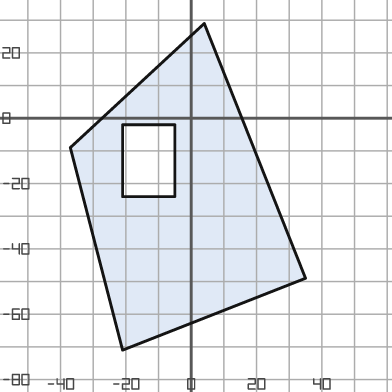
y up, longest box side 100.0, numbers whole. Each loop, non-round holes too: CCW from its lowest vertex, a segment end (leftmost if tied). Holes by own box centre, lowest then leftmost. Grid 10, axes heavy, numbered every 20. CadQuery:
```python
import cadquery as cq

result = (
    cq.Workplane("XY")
    .moveTo(-21.0, -71.0)
    .lineTo(35.0, -49.0)
    .lineTo(4.0, 29.0)
    .lineTo(-37.0, -9.0)
    .close()
    .moveTo(-21.0, -24.0)
    .lineTo(-5.0, -24.0)
    .lineTo(-5.0, -2.0)
    .lineTo(-21.0, -2.0)
    .close()
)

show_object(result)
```